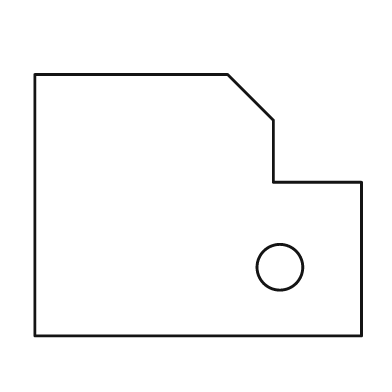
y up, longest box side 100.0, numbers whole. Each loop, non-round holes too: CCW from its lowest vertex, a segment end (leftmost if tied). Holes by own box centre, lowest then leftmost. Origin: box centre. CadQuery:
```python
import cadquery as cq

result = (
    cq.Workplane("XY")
    .moveTo(-50.0, -40.0)
    .lineTo(50.0, -40.0)
    .lineTo(50.0, 7.0)
    .lineTo(23.0, 7.0)
    .lineTo(23.0, 26.0)
    .lineTo(9.0, 40.0)
    .lineTo(-50.0, 40.0)
    .close()
    .moveTo(25.0, -19.0)
    .circle(7.0)
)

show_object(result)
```